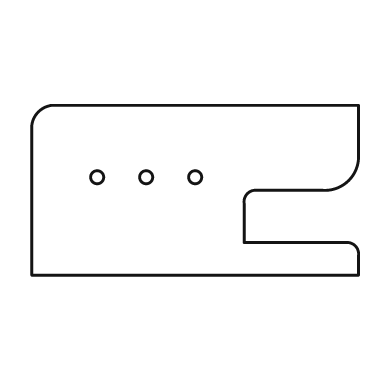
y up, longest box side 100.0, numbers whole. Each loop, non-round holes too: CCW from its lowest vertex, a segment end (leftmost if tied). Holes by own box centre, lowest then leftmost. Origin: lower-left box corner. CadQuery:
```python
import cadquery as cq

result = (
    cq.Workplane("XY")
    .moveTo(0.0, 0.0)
    .lineTo(100.0, 0.0)
    .lineTo(100.0, 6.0)
    .threePointArc((99.0, 9.0), (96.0, 10.0))
    .lineTo(65.0, 10.0)
    .lineTo(65.0, 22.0)
    .threePointArc((66.0, 25.0), (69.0, 26.0))
    .lineTo(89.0, 26.0)
    .threePointArc((97.0, 29.0), (100.0, 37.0))
    .lineTo(100.0, 52.0)
    .lineTo(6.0, 52.0)
    .threePointArc((2.0, 50.0), (0.0, 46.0))
    .close()
    .moveTo(20.0, 30.0)
    .circle(2.0)
    .moveTo(35.0, 30.0)
    .circle(2.0)
    .moveTo(50.0, 30.0)
    .circle(2.0)
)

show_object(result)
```